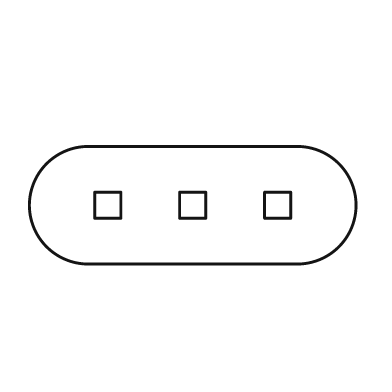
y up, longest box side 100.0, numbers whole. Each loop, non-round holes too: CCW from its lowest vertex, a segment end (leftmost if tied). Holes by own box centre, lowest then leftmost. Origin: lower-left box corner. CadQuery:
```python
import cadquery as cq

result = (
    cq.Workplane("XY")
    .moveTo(18.0, 0.0)
    .lineTo(82.0, 0.0)
    .threePointArc((100.0, 18.0), (82.0, 36.0))
    .lineTo(18.0, 36.0)
    .threePointArc((0.0, 18.0), (18.0, 0.0))
    .close()
    .moveTo(20.0, 14.0)
    .lineTo(28.0, 14.0)
    .lineTo(28.0, 22.0)
    .lineTo(20.0, 22.0)
    .close()
    .moveTo(46.0, 14.0)
    .lineTo(54.0, 14.0)
    .lineTo(54.0, 22.0)
    .lineTo(46.0, 22.0)
    .close()
    .moveTo(72.0, 14.0)
    .lineTo(80.0, 14.0)
    .lineTo(80.0, 22.0)
    .lineTo(72.0, 22.0)
    .close()
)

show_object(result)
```